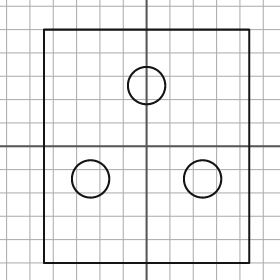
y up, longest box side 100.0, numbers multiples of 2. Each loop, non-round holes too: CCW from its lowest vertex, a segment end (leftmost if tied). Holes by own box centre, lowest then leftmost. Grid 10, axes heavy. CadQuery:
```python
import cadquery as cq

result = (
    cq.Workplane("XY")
    .moveTo(-44.0, -50.0)
    .lineTo(44.0, -50.0)
    .lineTo(44.0, 50.0)
    .lineTo(-44.0, 50.0)
    .close()
    .moveTo(-24.0, -14.0)
    .circle(8.0)
    .moveTo(24.0, -14.0)
    .circle(8.0)
    .moveTo(0.0, 26.0)
    .circle(8.0)
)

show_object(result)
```